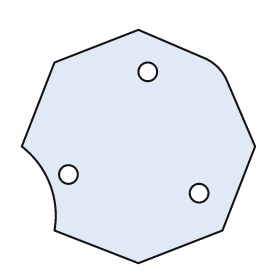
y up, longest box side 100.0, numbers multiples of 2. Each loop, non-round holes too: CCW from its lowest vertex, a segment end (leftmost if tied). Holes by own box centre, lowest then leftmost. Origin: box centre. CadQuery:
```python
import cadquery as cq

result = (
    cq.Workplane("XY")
    .moveTo(0.0, -50.0)
    .lineTo(36.0, -36.0)
    .lineTo(50.0, 0.0)
    .lineTo(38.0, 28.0)
    .threePointArc((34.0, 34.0), (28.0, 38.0))
    .lineTo(0.0, 50.0)
    .lineTo(-36.0, 36.0)
    .lineTo(-50.0, 0.0)
    .threePointArc((-38.0, -16.0), (-36.0, -36.0))
    .close()
    .moveTo(26.0, -20.0)
    .circle(4.0)
    .moveTo(-30.0, -12.0)
    .circle(4.0)
    .moveTo(4.0, 32.0)
    .circle(4.0)
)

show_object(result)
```